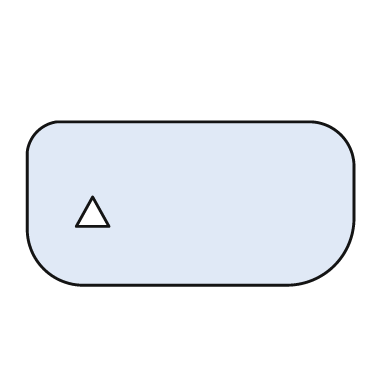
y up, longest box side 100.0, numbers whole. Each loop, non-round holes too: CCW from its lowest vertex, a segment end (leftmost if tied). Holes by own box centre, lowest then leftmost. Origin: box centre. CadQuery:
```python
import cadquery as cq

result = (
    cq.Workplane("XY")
    .moveTo(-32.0, -25.0)
    .lineTo(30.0, -25.0)
    .threePointArc((44.0, -19.0), (50.0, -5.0))
    .lineTo(50.0, 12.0)
    .threePointArc((46.0, 21.0), (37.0, 25.0))
    .lineTo(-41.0, 25.0)
    .threePointArc((-47.0, 22.0), (-50.0, 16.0))
    .lineTo(-50.0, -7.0)
    .threePointArc((-45.0, -20.0), (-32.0, -25.0))
    .close()
    .moveTo(-35.0, -7.0)
    .lineTo(-25.0, -7.0)
    .lineTo(-30.0, 2.0)
    .close()
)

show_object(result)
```